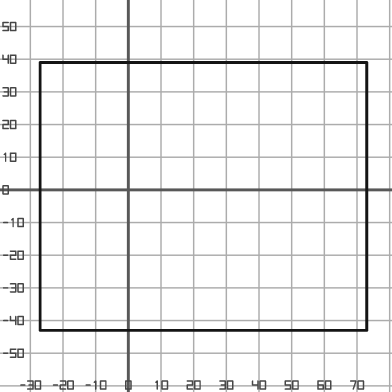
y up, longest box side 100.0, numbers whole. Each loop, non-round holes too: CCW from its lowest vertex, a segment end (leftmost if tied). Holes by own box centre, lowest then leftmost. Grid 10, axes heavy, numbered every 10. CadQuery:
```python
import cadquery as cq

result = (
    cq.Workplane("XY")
    .moveTo(-27.0, -43.0)
    .lineTo(73.0, -43.0)
    .lineTo(73.0, 39.0)
    .lineTo(-27.0, 39.0)
    .close()
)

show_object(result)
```